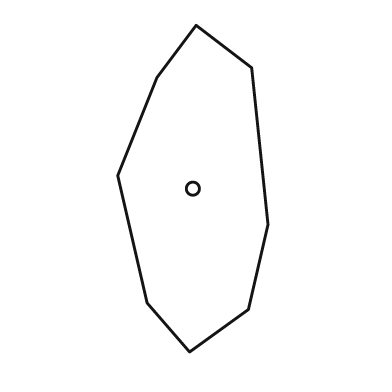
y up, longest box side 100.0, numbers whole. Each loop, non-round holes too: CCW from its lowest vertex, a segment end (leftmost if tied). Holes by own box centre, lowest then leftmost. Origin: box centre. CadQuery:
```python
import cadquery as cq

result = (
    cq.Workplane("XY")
    .moveTo(-1.0, -50.0)
    .lineTo(17.0, -37.0)
    .lineTo(23.0, -11.0)
    .lineTo(18.0, 37.0)
    .lineTo(1.0, 50.0)
    .lineTo(-11.0, 34.0)
    .lineTo(-23.0, 4.0)
    .lineTo(-14.0, -35.0)
    .close()
    .moveTo(0.0, 0.0)
    .circle(2.0)
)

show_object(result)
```